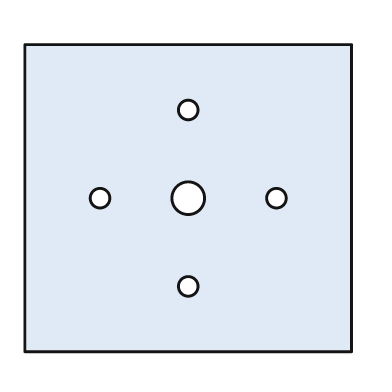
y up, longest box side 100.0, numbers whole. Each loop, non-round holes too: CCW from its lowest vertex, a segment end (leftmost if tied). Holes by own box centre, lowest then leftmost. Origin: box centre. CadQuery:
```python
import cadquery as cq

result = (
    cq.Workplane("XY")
    .moveTo(-50.0, -47.0)
    .lineTo(50.0, -47.0)
    .lineTo(50.0, 47.0)
    .lineTo(-50.0, 47.0)
    .close()
    .moveTo(0.0, -27.0)
    .circle(3.0)
    .moveTo(-27.0, 0.0)
    .circle(3.0)
    .moveTo(0.0, 0.0)
    .circle(5.0)
    .moveTo(27.0, 0.0)
    .circle(3.0)
    .moveTo(0.0, 27.0)
    .circle(3.0)
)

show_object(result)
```